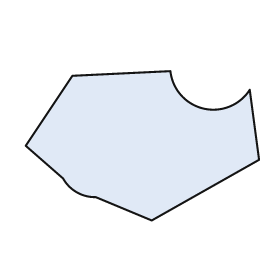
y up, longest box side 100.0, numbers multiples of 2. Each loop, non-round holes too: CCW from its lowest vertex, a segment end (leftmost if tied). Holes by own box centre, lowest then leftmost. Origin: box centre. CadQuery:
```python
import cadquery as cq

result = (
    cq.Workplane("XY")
    .moveTo(4.0, -32.0)
    .lineTo(50.0, -6.0)
    .lineTo(46.0, 24.0)
    .threePointArc((26.0, 16.0), (12.0, 32.0))
    .lineTo(-30.0, 30.0)
    .lineTo(-50.0, 0.0)
    .lineTo(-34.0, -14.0)
    .threePointArc((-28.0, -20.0), (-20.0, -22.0))
    .close()
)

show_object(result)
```